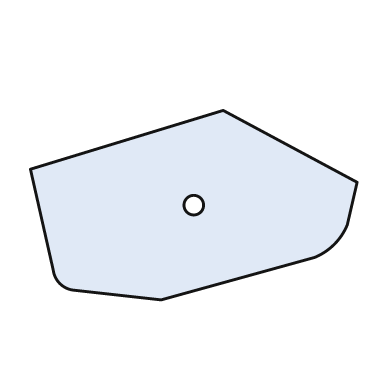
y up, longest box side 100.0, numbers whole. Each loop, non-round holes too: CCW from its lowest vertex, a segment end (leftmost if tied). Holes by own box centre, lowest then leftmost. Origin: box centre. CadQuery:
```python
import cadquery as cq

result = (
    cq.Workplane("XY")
    .moveTo(-10.0, -29.0)
    .lineTo(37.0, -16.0)
    .threePointArc((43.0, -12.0), (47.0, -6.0))
    .lineTo(50.0, 7.0)
    .lineTo(9.0, 29.0)
    .lineTo(-50.0, 11.0)
    .lineTo(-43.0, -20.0)
    .threePointArc((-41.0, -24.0), (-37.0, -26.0))
    .close()
    .moveTo(0.0, 0.0)
    .circle(3.0)
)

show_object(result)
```